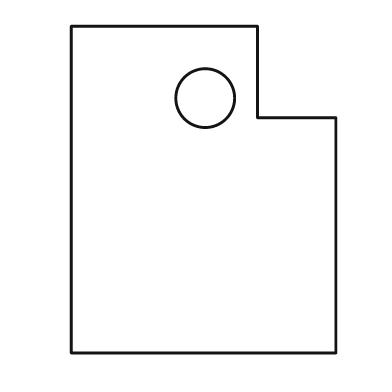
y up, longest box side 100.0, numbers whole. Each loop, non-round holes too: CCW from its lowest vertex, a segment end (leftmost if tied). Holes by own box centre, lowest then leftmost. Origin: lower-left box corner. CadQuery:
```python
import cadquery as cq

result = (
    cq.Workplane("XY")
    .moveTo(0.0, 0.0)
    .lineTo(81.0, 0.0)
    .lineTo(81.0, 72.0)
    .lineTo(57.0, 72.0)
    .lineTo(57.0, 100.0)
    .lineTo(0.0, 100.0)
    .close()
    .moveTo(41.0, 78.0)
    .circle(9.0)
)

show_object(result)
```